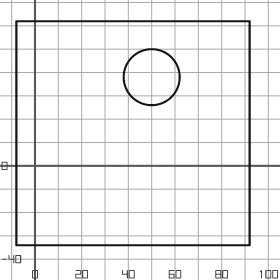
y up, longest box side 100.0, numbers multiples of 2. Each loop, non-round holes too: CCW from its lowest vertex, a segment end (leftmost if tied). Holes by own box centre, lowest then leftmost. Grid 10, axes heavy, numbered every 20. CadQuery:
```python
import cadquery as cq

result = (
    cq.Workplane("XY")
    .moveTo(-8.0, -34.0)
    .lineTo(92.0, -34.0)
    .lineTo(92.0, 62.0)
    .lineTo(-8.0, 62.0)
    .close()
    .moveTo(50.0, 38.0)
    .circle(12.0)
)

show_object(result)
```